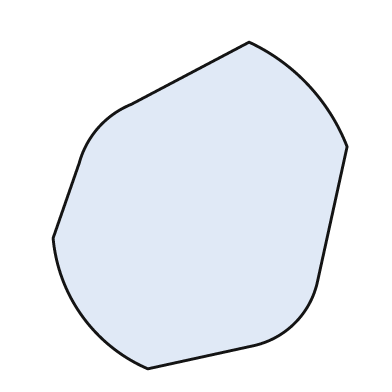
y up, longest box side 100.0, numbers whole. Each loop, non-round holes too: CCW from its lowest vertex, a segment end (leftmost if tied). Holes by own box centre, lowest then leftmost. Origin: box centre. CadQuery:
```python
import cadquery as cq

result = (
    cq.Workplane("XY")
    .moveTo(-16.0, -50.0)
    .lineTo(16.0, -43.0)
    .threePointArc((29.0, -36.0), (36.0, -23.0))
    .lineTo(45.0, 18.0)
    .threePointArc((33.0, 37.0), (15.0, 50.0))
    .lineTo(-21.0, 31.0)
    .threePointArc((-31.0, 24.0), (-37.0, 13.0))
    .lineTo(-45.0, -10.0)
    .threePointArc((-36.0, -34.0), (-16.0, -50.0))
    .close()
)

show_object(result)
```